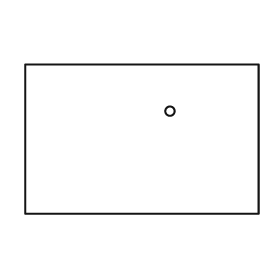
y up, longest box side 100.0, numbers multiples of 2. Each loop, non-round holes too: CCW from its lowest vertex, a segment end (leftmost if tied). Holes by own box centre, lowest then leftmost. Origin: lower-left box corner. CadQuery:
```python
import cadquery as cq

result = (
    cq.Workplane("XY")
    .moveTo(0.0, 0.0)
    .lineTo(100.0, 0.0)
    .lineTo(100.0, 64.0)
    .lineTo(0.0, 64.0)
    .close()
    .moveTo(62.0, 44.0)
    .circle(2.0)
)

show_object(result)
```